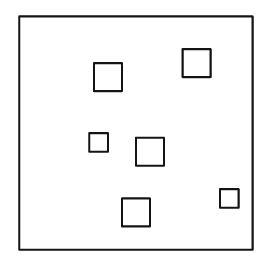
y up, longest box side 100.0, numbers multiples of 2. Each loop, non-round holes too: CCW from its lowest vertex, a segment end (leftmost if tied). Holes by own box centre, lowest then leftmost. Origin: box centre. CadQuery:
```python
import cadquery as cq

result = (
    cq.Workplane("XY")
    .moveTo(-50.0, -50.0)
    .lineTo(50.0, -50.0)
    .lineTo(50.0, 50.0)
    .lineTo(-50.0, 50.0)
    .close()
    .moveTo(-6.0, -40.0)
    .lineTo(6.0, -40.0)
    .lineTo(6.0, -28.0)
    .lineTo(-6.0, -28.0)
    .close()
    .moveTo(36.0, -32.0)
    .lineTo(44.0, -32.0)
    .lineTo(44.0, -24.0)
    .lineTo(36.0, -24.0)
    .close()
    .moveTo(0.0, -14.0)
    .lineTo(12.0, -14.0)
    .lineTo(12.0, -2.0)
    .lineTo(0.0, -2.0)
    .close()
    .moveTo(-20.0, -8.0)
    .lineTo(-12.0, -8.0)
    .lineTo(-12.0, 0.0)
    .lineTo(-20.0, 0.0)
    .close()
    .moveTo(-18.0, 18.0)
    .lineTo(-6.0, 18.0)
    .lineTo(-6.0, 30.0)
    .lineTo(-18.0, 30.0)
    .close()
    .moveTo(20.0, 24.0)
    .lineTo(32.0, 24.0)
    .lineTo(32.0, 36.0)
    .lineTo(20.0, 36.0)
    .close()
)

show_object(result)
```